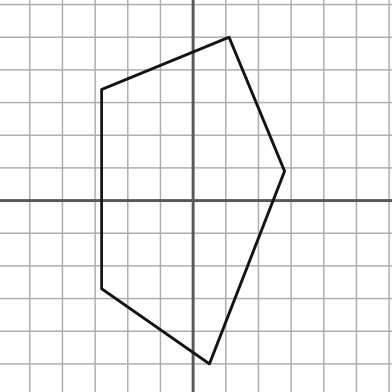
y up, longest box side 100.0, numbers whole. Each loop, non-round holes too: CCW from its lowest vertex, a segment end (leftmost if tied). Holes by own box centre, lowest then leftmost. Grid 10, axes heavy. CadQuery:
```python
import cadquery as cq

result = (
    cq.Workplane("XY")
    .moveTo(5.0, -50.0)
    .lineTo(28.0, 9.0)
    .lineTo(11.0, 50.0)
    .lineTo(-28.0, 34.0)
    .lineTo(-28.0, -27.0)
    .close()
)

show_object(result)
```